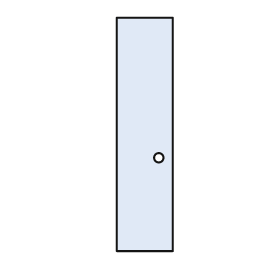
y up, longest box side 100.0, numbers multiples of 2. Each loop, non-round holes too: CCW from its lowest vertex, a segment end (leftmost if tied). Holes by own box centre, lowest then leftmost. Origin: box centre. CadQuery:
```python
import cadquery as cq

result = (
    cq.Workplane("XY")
    .moveTo(-12.0, -50.0)
    .lineTo(12.0, -50.0)
    .lineTo(12.0, 50.0)
    .lineTo(-12.0, 50.0)
    .close()
    .moveTo(6.0, -10.0)
    .circle(2.0)
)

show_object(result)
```